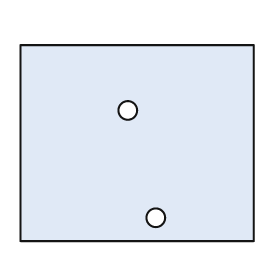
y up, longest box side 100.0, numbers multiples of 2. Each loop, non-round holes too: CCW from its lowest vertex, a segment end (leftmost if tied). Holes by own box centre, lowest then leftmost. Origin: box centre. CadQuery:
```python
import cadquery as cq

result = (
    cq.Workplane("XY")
    .moveTo(-50.0, -42.0)
    .lineTo(50.0, -42.0)
    .lineTo(50.0, 42.0)
    .lineTo(-50.0, 42.0)
    .close()
    .moveTo(8.0, -32.0)
    .circle(4.0)
    .moveTo(-4.0, 14.0)
    .circle(4.0)
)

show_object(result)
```